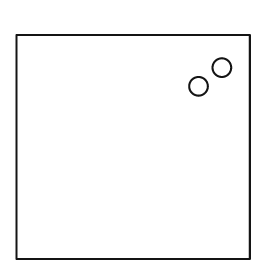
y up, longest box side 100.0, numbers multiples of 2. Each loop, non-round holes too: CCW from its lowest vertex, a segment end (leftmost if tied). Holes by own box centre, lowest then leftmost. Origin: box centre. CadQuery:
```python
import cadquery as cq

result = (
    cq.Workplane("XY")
    .moveTo(-50.0, -48.0)
    .lineTo(50.0, -48.0)
    .lineTo(50.0, 48.0)
    .lineTo(-50.0, 48.0)
    .close()
    .moveTo(28.0, 26.0)
    .circle(4.0)
    .moveTo(38.0, 34.0)
    .circle(4.0)
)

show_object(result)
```